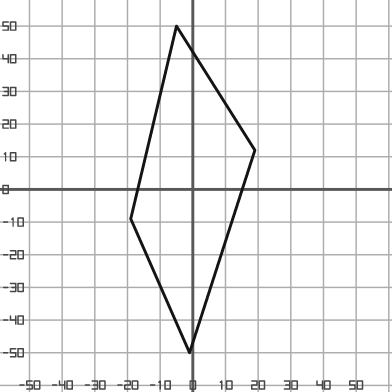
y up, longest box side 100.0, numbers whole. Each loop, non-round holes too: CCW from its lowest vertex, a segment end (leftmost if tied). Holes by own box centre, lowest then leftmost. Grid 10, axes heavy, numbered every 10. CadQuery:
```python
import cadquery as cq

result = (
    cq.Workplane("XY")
    .moveTo(-1.0, -50.0)
    .lineTo(19.0, 12.0)
    .lineTo(-5.0, 50.0)
    .lineTo(-19.0, -9.0)
    .close()
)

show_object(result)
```